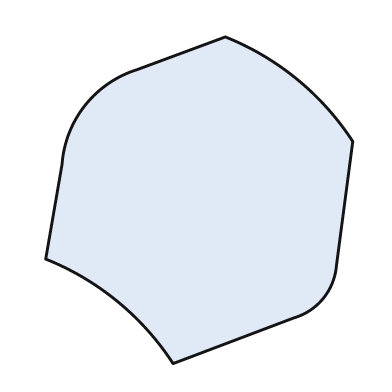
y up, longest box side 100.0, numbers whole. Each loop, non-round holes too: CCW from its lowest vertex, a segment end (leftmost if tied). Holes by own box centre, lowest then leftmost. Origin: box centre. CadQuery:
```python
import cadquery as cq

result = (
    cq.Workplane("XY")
    .moveTo(-8.0, -50.0)
    .lineTo(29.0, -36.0)
    .threePointArc((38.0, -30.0), (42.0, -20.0))
    .lineTo(47.0, 18.0)
    .threePointArc((30.0, 37.0), (8.0, 50.0))
    .lineTo(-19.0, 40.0)
    .threePointArc((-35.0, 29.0), (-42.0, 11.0))
    .lineTo(-47.0, -18.0)
    .threePointArc((-25.0, -31.0), (-8.0, -50.0))
    .close()
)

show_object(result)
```